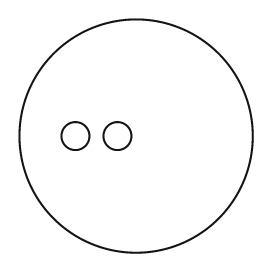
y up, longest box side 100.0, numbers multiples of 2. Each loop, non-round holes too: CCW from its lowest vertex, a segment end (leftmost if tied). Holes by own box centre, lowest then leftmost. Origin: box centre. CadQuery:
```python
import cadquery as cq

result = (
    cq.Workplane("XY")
    .moveTo(0.0, 0.0)
    .circle(50.0)
    .moveTo(-26.0, 0.0)
    .circle(6.0)
    .moveTo(-8.0, 0.0)
    .circle(6.0)
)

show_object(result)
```